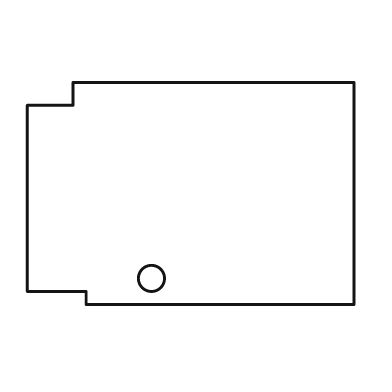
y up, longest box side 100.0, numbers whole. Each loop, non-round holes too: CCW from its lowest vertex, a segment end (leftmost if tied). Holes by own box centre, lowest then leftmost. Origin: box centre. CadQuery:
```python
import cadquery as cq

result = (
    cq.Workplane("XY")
    .moveTo(-32.0, -34.0)
    .lineTo(50.0, -34.0)
    .lineTo(50.0, 34.0)
    .lineTo(-36.0, 34.0)
    .lineTo(-36.0, 27.0)
    .lineTo(-50.0, 27.0)
    .lineTo(-50.0, -30.0)
    .lineTo(-32.0, -30.0)
    .close()
    .moveTo(-12.0, -26.0)
    .circle(4.0)
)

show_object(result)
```